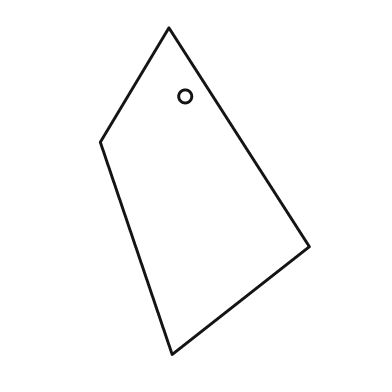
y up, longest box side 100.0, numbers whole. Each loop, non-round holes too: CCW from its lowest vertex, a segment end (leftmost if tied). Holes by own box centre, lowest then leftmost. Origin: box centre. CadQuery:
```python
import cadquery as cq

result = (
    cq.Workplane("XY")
    .moveTo(-10.0, -50.0)
    .lineTo(32.0, -17.0)
    .lineTo(-11.0, 50.0)
    .lineTo(-32.0, 15.0)
    .close()
    .moveTo(-6.0, 29.0)
    .circle(2.0)
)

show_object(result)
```